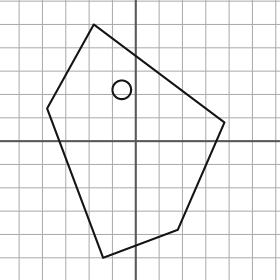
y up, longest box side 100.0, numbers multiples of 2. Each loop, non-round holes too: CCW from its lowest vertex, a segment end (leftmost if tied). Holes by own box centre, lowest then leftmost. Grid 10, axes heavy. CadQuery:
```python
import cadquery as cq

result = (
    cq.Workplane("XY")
    .moveTo(-14.0, -50.0)
    .lineTo(18.0, -38.0)
    .lineTo(38.0, 8.0)
    .lineTo(-18.0, 50.0)
    .lineTo(-38.0, 14.0)
    .close()
    .moveTo(-6.0, 22.0)
    .circle(4.0)
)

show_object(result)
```